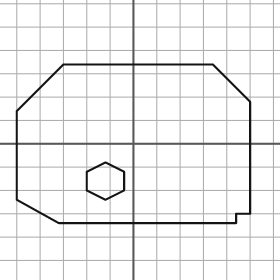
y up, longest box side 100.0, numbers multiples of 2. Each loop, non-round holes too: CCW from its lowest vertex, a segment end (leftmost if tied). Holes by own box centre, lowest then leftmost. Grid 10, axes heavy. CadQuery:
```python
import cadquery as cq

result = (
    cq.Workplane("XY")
    .moveTo(-32.0, -34.0)
    .lineTo(44.0, -34.0)
    .lineTo(44.0, -30.0)
    .lineTo(50.0, -30.0)
    .lineTo(50.0, 18.0)
    .lineTo(34.0, 34.0)
    .lineTo(-30.0, 34.0)
    .lineTo(-50.0, 14.0)
    .lineTo(-50.0, -24.0)
    .close()
    .moveTo(-12.0, -24.0)
    .lineTo(-4.0, -20.0)
    .lineTo(-4.0, -12.0)
    .lineTo(-12.0, -8.0)
    .lineTo(-20.0, -12.0)
    .lineTo(-20.0, -20.0)
    .close()
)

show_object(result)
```